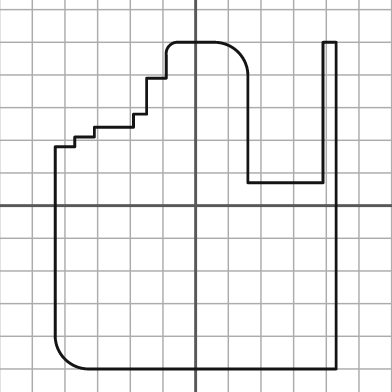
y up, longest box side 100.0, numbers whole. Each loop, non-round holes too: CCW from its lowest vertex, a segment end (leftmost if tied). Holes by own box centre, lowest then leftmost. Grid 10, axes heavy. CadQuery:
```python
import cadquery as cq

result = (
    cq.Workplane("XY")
    .moveTo(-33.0, -50.0)
    .lineTo(43.0, -50.0)
    .lineTo(43.0, 50.0)
    .lineTo(39.0, 50.0)
    .lineTo(39.0, 7.0)
    .lineTo(16.0, 7.0)
    .lineTo(16.0, 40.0)
    .threePointArc((13.0, 47.0), (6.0, 50.0))
    .lineTo(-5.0, 50.0)
    .threePointArc((-8.0, 49.0), (-9.0, 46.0))
    .lineTo(-9.0, 39.0)
    .lineTo(-15.0, 39.0)
    .lineTo(-15.0, 28.0)
    .lineTo(-19.0, 28.0)
    .lineTo(-19.0, 24.0)
    .lineTo(-31.0, 24.0)
    .lineTo(-31.0, 21.0)
    .lineTo(-37.0, 21.0)
    .lineTo(-37.0, 18.0)
    .lineTo(-43.0, 18.0)
    .lineTo(-43.0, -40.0)
    .threePointArc((-40.0, -47.0), (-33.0, -50.0))
    .close()
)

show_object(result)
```